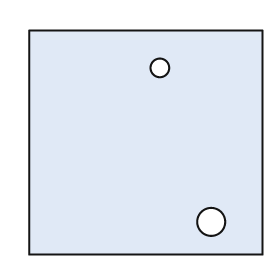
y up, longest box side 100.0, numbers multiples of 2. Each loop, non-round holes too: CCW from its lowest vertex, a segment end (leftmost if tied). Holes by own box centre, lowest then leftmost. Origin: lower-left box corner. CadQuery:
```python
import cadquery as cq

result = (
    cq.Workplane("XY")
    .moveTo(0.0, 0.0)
    .lineTo(100.0, 0.0)
    .lineTo(100.0, 96.0)
    .lineTo(0.0, 96.0)
    .close()
    .moveTo(78.0, 14.0)
    .circle(6.0)
    .moveTo(56.0, 80.0)
    .circle(4.0)
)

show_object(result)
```